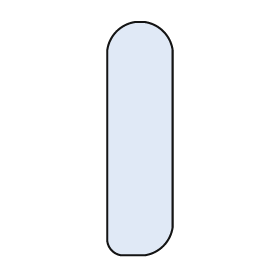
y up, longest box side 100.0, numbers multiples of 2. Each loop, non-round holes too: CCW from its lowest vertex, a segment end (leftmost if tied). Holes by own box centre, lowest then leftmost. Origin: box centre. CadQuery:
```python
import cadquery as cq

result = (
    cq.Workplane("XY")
    .moveTo(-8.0, -50.0)
    .lineTo(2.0, -50.0)
    .threePointArc((10.0, -46.0), (14.0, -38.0))
    .lineTo(14.0, 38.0)
    .threePointArc((10.0, 46.0), (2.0, 50.0))
    .lineTo(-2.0, 50.0)
    .threePointArc((-10.0, 46.0), (-14.0, 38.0))
    .lineTo(-14.0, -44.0)
    .threePointArc((-12.0, -48.0), (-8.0, -50.0))
    .close()
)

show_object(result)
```